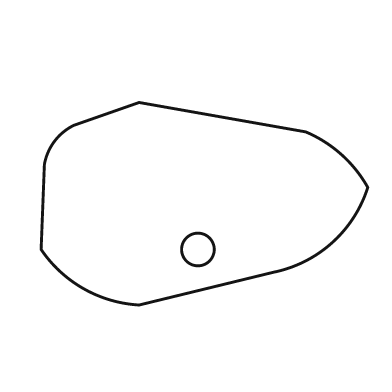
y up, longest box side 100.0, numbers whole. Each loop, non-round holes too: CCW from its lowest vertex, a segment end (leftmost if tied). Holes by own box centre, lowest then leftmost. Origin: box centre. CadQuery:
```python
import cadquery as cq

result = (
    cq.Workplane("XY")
    .moveTo(-20.0, -31.0)
    .lineTo(21.0, -21.0)
    .threePointArc((39.0, -12.0), (50.0, 5.0))
    .threePointArc((42.0, 15.0), (31.0, 22.0))
    .lineTo(-20.0, 31.0)
    .lineTo(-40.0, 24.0)
    .threePointArc((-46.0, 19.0), (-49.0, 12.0))
    .lineTo(-50.0, -14.0)
    .threePointArc((-37.0, -26.0), (-20.0, -31.0))
    .close()
    .moveTo(-2.0, -14.0)
    .circle(5.0)
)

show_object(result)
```